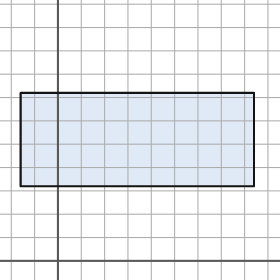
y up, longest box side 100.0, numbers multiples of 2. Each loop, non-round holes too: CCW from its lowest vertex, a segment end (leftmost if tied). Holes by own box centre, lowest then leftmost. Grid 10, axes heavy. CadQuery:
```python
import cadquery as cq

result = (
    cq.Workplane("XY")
    .moveTo(-16.0, 32.0)
    .lineTo(84.0, 32.0)
    .lineTo(84.0, 72.0)
    .lineTo(-16.0, 72.0)
    .close()
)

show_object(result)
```